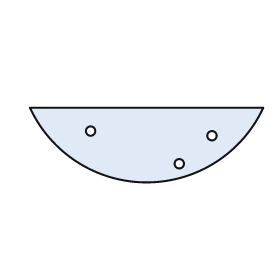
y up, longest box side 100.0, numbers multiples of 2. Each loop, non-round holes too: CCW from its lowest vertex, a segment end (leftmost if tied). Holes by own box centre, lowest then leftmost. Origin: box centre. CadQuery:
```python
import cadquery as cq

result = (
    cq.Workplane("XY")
    .moveTo(-50.0, 16.0)
    .threePointArc((0.0, -16.0), (50.0, 16.0))
    .close()
    .moveTo(14.0, -8.0)
    .circle(2.0)
    .moveTo(28.0, 4.0)
    .circle(2.0)
    .moveTo(-24.0, 6.0)
    .circle(2.0)
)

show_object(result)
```